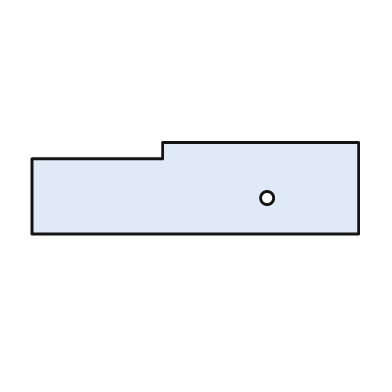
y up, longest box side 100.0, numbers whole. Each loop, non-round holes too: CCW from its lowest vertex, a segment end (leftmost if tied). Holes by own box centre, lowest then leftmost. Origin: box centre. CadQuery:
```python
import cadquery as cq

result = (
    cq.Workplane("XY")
    .moveTo(-50.0, -14.0)
    .lineTo(50.0, -14.0)
    .lineTo(50.0, 14.0)
    .lineTo(-10.0, 14.0)
    .lineTo(-10.0, 9.0)
    .lineTo(-50.0, 9.0)
    .close()
    .moveTo(22.0, -3.0)
    .circle(2.0)
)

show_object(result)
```